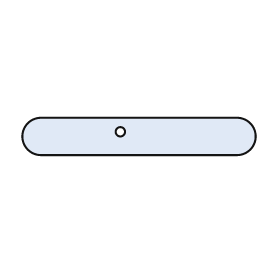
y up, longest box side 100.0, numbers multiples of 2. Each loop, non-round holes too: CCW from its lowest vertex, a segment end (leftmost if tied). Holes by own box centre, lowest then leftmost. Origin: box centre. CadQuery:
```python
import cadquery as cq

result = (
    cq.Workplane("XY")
    .moveTo(-42.0, -8.0)
    .lineTo(42.0, -8.0)
    .threePointArc((50.0, 0.0), (42.0, 8.0))
    .lineTo(-42.0, 8.0)
    .threePointArc((-50.0, 0.0), (-42.0, -8.0))
    .close()
    .moveTo(-8.0, 2.0)
    .circle(2.0)
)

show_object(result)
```